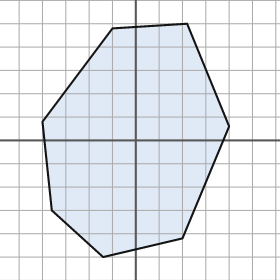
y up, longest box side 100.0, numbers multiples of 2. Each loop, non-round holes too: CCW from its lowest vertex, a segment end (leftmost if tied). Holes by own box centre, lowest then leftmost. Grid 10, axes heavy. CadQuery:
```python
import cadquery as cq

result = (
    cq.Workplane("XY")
    .moveTo(-14.0, -50.0)
    .lineTo(20.0, -42.0)
    .lineTo(40.0, 6.0)
    .lineTo(22.0, 50.0)
    .lineTo(-10.0, 48.0)
    .lineTo(-40.0, 8.0)
    .lineTo(-36.0, -30.0)
    .close()
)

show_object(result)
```